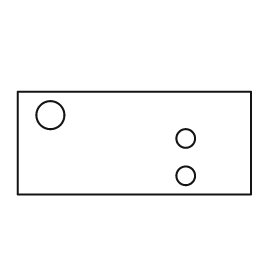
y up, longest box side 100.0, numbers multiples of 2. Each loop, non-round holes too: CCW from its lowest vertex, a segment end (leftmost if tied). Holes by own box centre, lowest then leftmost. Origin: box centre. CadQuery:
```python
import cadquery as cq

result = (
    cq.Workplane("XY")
    .moveTo(-50.0, -22.0)
    .lineTo(50.0, -22.0)
    .lineTo(50.0, 22.0)
    .lineTo(-50.0, 22.0)
    .close()
    .moveTo(22.0, -14.0)
    .circle(4.0)
    .moveTo(22.0, 2.0)
    .circle(4.0)
    .moveTo(-36.0, 12.0)
    .circle(6.0)
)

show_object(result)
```